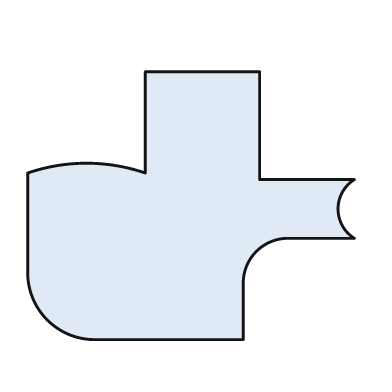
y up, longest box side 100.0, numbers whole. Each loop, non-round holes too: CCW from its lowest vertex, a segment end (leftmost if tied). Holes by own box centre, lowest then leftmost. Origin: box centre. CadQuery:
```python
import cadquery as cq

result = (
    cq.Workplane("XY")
    .moveTo(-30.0, -41.0)
    .lineTo(16.0, -41.0)
    .lineTo(16.0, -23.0)
    .threePointArc((20.0, -14.0), (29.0, -10.0))
    .lineTo(50.0, -10.0)
    .threePointArc((45.0, -1.0), (50.0, 8.0))
    .lineTo(21.0, 8.0)
    .lineTo(21.0, 41.0)
    .lineTo(-14.0, 41.0)
    .lineTo(-14.0, 10.0)
    .threePointArc((-32.0, 13.0), (-50.0, 10.0))
    .lineTo(-50.0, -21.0)
    .threePointArc((-44.0, -35.0), (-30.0, -41.0))
    .close()
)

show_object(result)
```